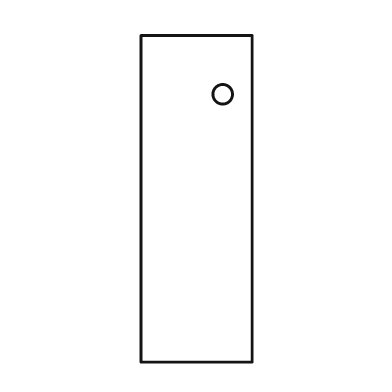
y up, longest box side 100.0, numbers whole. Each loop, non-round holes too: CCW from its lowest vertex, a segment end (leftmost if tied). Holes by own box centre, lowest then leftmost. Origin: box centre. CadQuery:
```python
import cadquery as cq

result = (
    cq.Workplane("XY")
    .moveTo(-17.0, -50.0)
    .lineTo(17.0, -50.0)
    .lineTo(17.0, 50.0)
    .lineTo(-17.0, 50.0)
    .close()
    .moveTo(8.0, 32.0)
    .circle(3.0)
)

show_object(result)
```